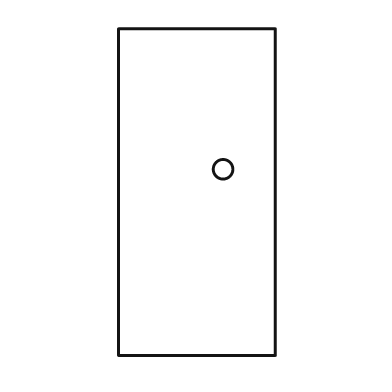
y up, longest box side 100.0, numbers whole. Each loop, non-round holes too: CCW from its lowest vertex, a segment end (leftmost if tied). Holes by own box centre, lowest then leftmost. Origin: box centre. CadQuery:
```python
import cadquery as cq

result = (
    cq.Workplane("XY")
    .moveTo(-24.0, -50.0)
    .lineTo(24.0, -50.0)
    .lineTo(24.0, 50.0)
    .lineTo(-24.0, 50.0)
    .close()
    .moveTo(8.0, 7.0)
    .circle(3.0)
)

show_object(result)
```